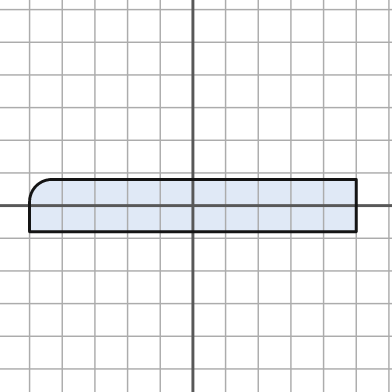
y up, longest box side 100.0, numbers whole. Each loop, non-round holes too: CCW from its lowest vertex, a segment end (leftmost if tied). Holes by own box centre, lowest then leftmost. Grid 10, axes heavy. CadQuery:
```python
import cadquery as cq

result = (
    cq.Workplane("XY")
    .moveTo(-50.0, -8.0)
    .lineTo(50.0, -8.0)
    .lineTo(50.0, 8.0)
    .lineTo(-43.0, 8.0)
    .threePointArc((-48.0, 6.0), (-50.0, 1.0))
    .close()
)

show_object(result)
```